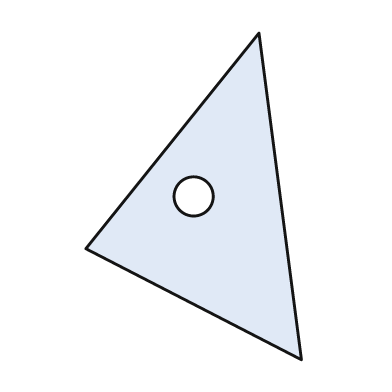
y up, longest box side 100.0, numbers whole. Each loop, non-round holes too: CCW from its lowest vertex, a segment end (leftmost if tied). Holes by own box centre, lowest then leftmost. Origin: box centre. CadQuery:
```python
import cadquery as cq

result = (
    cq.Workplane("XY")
    .moveTo(33.0, -50.0)
    .lineTo(20.0, 50.0)
    .lineTo(-33.0, -16.0)
    .close()
    .moveTo(0.0, 0.0)
    .circle(6.0)
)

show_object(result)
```